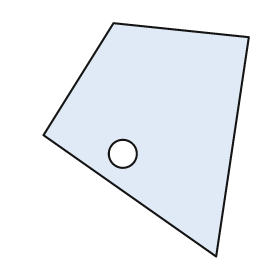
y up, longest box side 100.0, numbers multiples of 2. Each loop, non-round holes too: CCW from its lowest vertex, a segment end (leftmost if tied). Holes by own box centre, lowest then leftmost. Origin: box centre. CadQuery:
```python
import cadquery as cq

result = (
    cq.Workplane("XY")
    .moveTo(30.0, -50.0)
    .lineTo(44.0, 44.0)
    .lineTo(-14.0, 50.0)
    .lineTo(-44.0, 2.0)
    .close()
    .moveTo(-10.0, -6.0)
    .circle(6.0)
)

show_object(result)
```